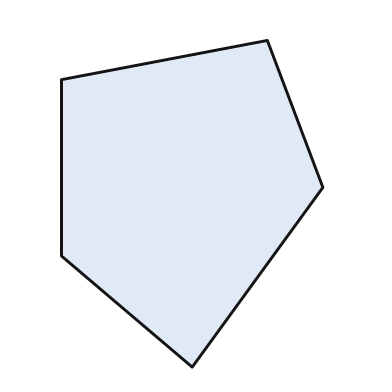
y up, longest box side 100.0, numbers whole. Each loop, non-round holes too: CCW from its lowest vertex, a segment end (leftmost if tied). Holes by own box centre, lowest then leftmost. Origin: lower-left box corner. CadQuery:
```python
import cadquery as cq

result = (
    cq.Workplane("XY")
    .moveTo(40.0, 0.0)
    .lineTo(80.0, 55.0)
    .lineTo(63.0, 100.0)
    .lineTo(0.0, 88.0)
    .lineTo(0.0, 34.0)
    .close()
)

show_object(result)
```